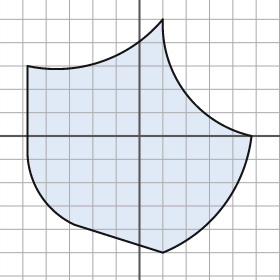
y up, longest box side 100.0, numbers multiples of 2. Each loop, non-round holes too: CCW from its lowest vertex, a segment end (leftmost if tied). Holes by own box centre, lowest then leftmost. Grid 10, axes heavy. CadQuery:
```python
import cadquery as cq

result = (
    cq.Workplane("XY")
    .moveTo(10.0, -50.0)
    .threePointArc((36.0, -30.0), (48.0, 0.0))
    .threePointArc((20.0, 18.0), (10.0, 50.0))
    .threePointArc((-16.0, 32.0), (-48.0, 30.0))
    .lineTo(-48.0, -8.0)
    .threePointArc((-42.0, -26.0), (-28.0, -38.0))
    .close()
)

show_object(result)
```